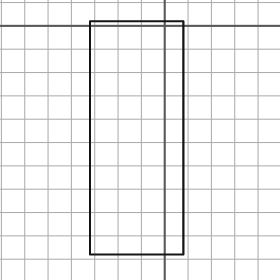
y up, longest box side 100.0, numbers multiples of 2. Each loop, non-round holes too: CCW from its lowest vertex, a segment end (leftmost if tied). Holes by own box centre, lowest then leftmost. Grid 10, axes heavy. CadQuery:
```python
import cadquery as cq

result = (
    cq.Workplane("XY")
    .moveTo(-32.0, -98.0)
    .lineTo(8.0, -98.0)
    .lineTo(8.0, 2.0)
    .lineTo(-32.0, 2.0)
    .close()
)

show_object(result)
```